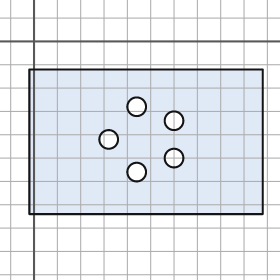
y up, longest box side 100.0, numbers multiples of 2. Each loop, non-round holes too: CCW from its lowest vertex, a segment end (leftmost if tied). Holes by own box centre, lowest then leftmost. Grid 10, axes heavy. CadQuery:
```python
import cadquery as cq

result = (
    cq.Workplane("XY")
    .moveTo(-2.0, -74.0)
    .lineTo(98.0, -74.0)
    .lineTo(98.0, -12.0)
    .lineTo(-2.0, -12.0)
    .close()
    .moveTo(44.0, -56.0)
    .circle(4.0)
    .moveTo(60.0, -50.0)
    .circle(4.0)
    .moveTo(32.0, -42.0)
    .circle(4.0)
    .moveTo(60.0, -34.0)
    .circle(4.0)
    .moveTo(44.0, -28.0)
    .circle(4.0)
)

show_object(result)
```